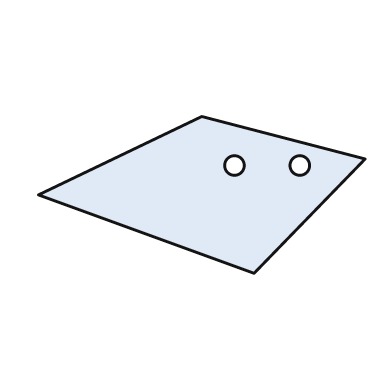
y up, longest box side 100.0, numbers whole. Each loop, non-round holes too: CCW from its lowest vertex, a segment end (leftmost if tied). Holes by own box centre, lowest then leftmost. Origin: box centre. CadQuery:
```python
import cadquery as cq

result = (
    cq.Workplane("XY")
    .moveTo(16.0, -24.0)
    .lineTo(50.0, 11.0)
    .lineTo(0.0, 24.0)
    .lineTo(-50.0, 0.0)
    .close()
    .moveTo(10.0, 9.0)
    .circle(3.0)
    .moveTo(30.0, 9.0)
    .circle(3.0)
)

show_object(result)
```